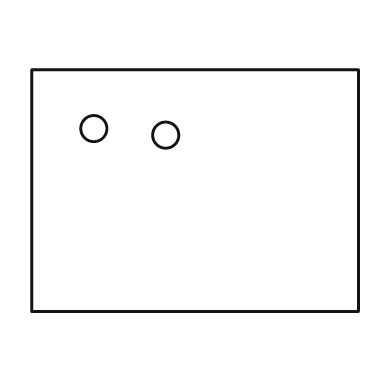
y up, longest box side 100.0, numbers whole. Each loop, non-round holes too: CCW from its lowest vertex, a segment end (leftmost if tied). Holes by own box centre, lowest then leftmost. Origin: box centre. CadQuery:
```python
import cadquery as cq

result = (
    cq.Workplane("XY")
    .moveTo(-50.0, -37.0)
    .lineTo(50.0, -37.0)
    .lineTo(50.0, 37.0)
    .lineTo(-50.0, 37.0)
    .close()
    .moveTo(-9.0, 17.0)
    .circle(4.0)
    .moveTo(-31.0, 19.0)
    .circle(4.0)
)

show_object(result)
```